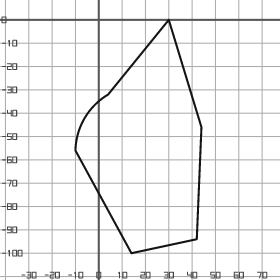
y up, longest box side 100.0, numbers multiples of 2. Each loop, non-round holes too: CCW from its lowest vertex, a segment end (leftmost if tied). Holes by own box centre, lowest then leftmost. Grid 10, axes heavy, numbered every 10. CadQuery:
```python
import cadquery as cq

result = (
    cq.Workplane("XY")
    .moveTo(14.0, -100.0)
    .lineTo(42.0, -94.0)
    .lineTo(44.0, -46.0)
    .lineTo(30.0, 0.0)
    .lineTo(4.0, -32.0)
    .threePointArc((-6.0, -42.0), (-10.0, -56.0))
    .close()
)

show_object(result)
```